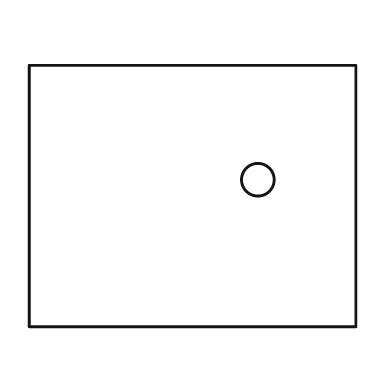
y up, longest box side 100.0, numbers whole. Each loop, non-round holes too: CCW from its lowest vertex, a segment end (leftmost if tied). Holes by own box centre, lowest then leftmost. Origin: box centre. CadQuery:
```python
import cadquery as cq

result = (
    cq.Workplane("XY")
    .moveTo(-50.0, -40.0)
    .lineTo(50.0, -40.0)
    .lineTo(50.0, 40.0)
    .lineTo(-50.0, 40.0)
    .close()
    .moveTo(20.0, 5.0)
    .circle(5.0)
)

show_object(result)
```